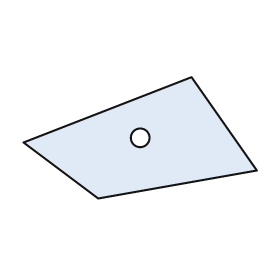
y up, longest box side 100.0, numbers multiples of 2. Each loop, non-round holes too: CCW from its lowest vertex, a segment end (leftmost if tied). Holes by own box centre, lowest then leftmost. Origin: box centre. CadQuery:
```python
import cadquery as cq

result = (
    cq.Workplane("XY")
    .moveTo(-18.0, -26.0)
    .lineTo(50.0, -14.0)
    .lineTo(22.0, 26.0)
    .lineTo(-50.0, -2.0)
    .close()
    .moveTo(0.0, 0.0)
    .circle(4.0)
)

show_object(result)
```